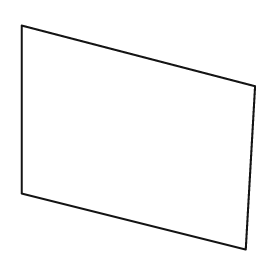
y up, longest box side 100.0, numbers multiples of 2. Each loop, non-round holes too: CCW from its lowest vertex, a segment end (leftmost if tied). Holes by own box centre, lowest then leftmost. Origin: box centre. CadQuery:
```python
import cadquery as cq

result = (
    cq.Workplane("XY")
    .moveTo(46.0, -48.0)
    .lineTo(50.0, 22.0)
    .lineTo(-50.0, 48.0)
    .lineTo(-50.0, -24.0)
    .close()
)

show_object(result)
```